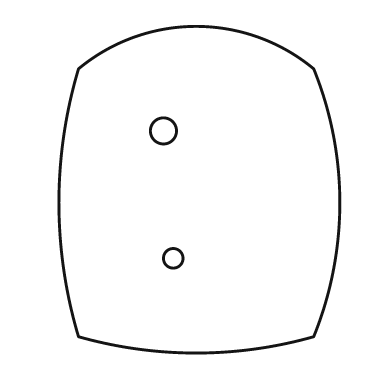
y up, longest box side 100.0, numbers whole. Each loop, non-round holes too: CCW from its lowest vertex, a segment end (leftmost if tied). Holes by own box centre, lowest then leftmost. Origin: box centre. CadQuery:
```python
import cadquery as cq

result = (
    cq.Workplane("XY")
    .moveTo(-37.0, -45.0)
    .threePointArc((-1.0, -50.0), (35.0, -45.0))
    .threePointArc((43.0, -4.0), (35.0, 37.0))
    .threePointArc((-1.0, 50.0), (-37.0, 37.0))
    .threePointArc((-43.0, -4.0), (-37.0, -45.0))
    .close()
    .moveTo(-8.0, -21.0)
    .circle(3.0)
    .moveTo(-11.0, 18.0)
    .circle(4.0)
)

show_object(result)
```